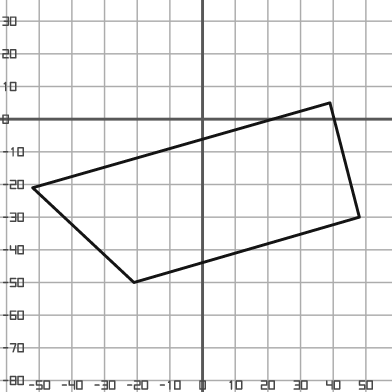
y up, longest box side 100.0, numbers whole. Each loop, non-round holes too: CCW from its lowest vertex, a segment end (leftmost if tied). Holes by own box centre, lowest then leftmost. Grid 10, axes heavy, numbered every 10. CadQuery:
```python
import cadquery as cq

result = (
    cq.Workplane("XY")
    .moveTo(-21.0, -50.0)
    .lineTo(48.0, -30.0)
    .lineTo(39.0, 5.0)
    .lineTo(-52.0, -21.0)
    .close()
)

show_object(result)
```